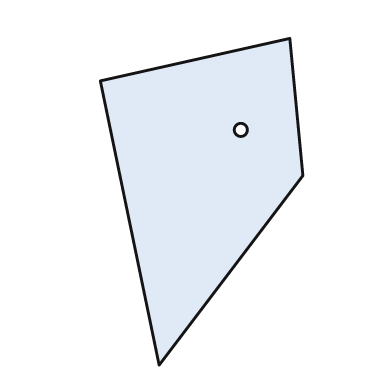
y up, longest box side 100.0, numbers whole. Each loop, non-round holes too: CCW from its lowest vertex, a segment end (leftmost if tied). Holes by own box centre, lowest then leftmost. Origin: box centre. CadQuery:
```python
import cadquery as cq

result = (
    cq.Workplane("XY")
    .moveTo(-13.0, -50.0)
    .lineTo(31.0, 8.0)
    .lineTo(27.0, 50.0)
    .lineTo(-31.0, 37.0)
    .close()
    .moveTo(12.0, 22.0)
    .circle(2.0)
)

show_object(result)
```